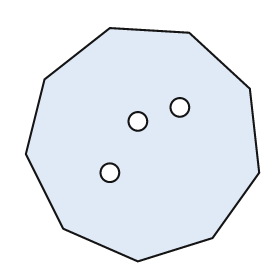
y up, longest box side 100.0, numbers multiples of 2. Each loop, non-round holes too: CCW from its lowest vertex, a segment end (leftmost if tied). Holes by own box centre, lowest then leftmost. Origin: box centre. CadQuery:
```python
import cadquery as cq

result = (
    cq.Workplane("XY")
    .moveTo(-2.0, -50.0)
    .lineTo(30.0, -40.0)
    .lineTo(50.0, -12.0)
    .lineTo(46.0, 24.0)
    .lineTo(20.0, 48.0)
    .lineTo(-14.0, 50.0)
    .lineTo(-42.0, 28.0)
    .lineTo(-50.0, -4.0)
    .lineTo(-34.0, -36.0)
    .close()
    .moveTo(-14.0, -12.0)
    .circle(4.0)
    .moveTo(-2.0, 10.0)
    .circle(4.0)
    .moveTo(16.0, 16.0)
    .circle(4.0)
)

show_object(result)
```